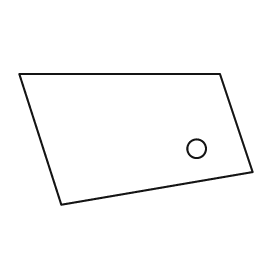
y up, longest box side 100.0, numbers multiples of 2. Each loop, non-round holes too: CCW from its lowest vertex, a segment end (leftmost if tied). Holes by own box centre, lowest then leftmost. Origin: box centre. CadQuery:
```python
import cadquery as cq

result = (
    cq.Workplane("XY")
    .moveTo(-32.0, -28.0)
    .lineTo(50.0, -14.0)
    .lineTo(36.0, 28.0)
    .lineTo(-50.0, 28.0)
    .close()
    .moveTo(26.0, -4.0)
    .circle(4.0)
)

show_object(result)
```